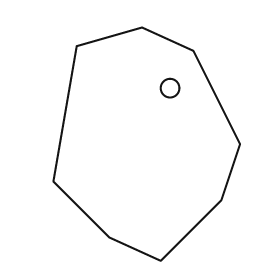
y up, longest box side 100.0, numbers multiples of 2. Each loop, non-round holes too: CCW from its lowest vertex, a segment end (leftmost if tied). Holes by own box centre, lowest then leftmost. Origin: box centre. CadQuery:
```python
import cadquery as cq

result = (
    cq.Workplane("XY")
    .moveTo(6.0, -50.0)
    .lineTo(32.0, -24.0)
    .lineTo(40.0, 0.0)
    .lineTo(20.0, 40.0)
    .lineTo(-2.0, 50.0)
    .lineTo(-30.0, 42.0)
    .lineTo(-40.0, -16.0)
    .lineTo(-16.0, -40.0)
    .close()
    .moveTo(10.0, 24.0)
    .circle(4.0)
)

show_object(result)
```